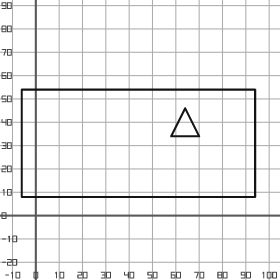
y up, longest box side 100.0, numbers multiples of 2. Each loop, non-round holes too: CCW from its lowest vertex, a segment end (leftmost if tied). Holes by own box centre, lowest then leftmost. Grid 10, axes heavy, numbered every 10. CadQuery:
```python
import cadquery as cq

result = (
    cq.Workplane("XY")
    .moveTo(-6.0, 8.0)
    .lineTo(94.0, 8.0)
    .lineTo(94.0, 54.0)
    .lineTo(-6.0, 54.0)
    .close()
    .moveTo(58.0, 34.0)
    .lineTo(70.0, 34.0)
    .lineTo(64.0, 46.0)
    .close()
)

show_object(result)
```